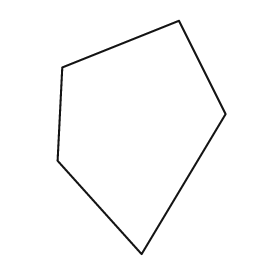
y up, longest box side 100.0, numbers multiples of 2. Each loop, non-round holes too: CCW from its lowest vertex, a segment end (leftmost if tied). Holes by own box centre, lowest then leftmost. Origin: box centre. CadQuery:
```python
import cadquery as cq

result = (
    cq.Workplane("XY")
    .moveTo(0.0, -50.0)
    .lineTo(36.0, 10.0)
    .lineTo(16.0, 50.0)
    .lineTo(-34.0, 30.0)
    .lineTo(-36.0, -10.0)
    .close()
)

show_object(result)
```